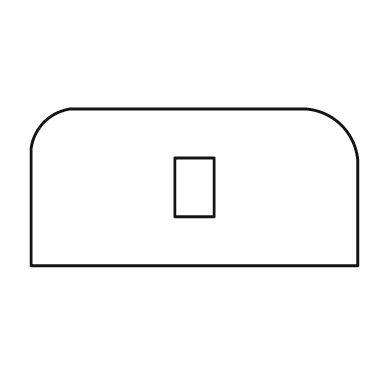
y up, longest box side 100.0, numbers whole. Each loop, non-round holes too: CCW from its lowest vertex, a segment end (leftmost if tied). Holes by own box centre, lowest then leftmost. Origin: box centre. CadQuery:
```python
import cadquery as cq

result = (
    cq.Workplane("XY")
    .moveTo(-50.0, -24.0)
    .lineTo(50.0, -24.0)
    .lineTo(50.0, 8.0)
    .threePointArc((45.0, 19.0), (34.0, 24.0))
    .lineTo(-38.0, 24.0)
    .threePointArc((-46.0, 20.0), (-50.0, 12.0))
    .close()
    .moveTo(-6.0, -9.0)
    .lineTo(6.0, -9.0)
    .lineTo(6.0, 9.0)
    .lineTo(-6.0, 9.0)
    .close()
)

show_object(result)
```